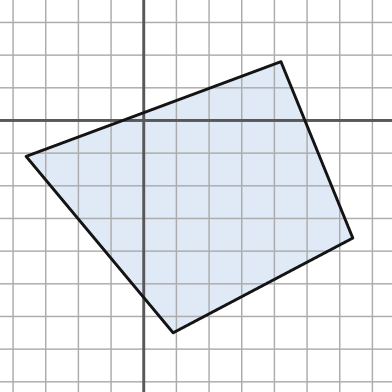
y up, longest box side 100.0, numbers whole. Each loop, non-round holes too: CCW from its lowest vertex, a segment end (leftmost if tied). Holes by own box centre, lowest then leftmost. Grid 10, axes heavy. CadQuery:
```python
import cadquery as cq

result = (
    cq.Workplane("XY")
    .moveTo(9.0, -65.0)
    .lineTo(64.0, -36.0)
    .lineTo(42.0, 18.0)
    .lineTo(-36.0, -11.0)
    .close()
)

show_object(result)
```